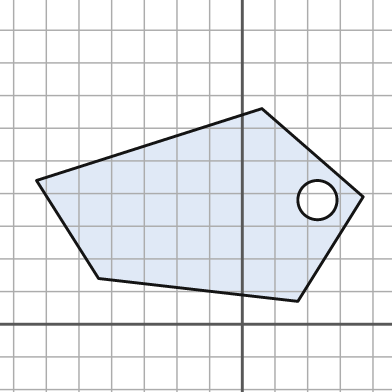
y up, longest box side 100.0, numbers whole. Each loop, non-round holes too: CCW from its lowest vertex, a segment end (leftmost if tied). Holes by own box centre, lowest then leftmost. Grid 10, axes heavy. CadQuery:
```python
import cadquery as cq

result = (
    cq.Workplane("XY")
    .moveTo(17.0, 7.0)
    .lineTo(37.0, 39.0)
    .lineTo(6.0, 66.0)
    .lineTo(-63.0, 44.0)
    .lineTo(-44.0, 14.0)
    .close()
    .moveTo(23.0, 38.0)
    .circle(6.0)
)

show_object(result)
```